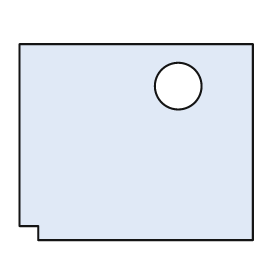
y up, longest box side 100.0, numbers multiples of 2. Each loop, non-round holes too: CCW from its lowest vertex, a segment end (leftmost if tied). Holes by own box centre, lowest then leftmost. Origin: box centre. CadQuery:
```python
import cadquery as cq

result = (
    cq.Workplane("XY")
    .moveTo(-42.0, -42.0)
    .lineTo(50.0, -42.0)
    .lineTo(50.0, 42.0)
    .lineTo(-50.0, 42.0)
    .lineTo(-50.0, -36.0)
    .lineTo(-42.0, -36.0)
    .close()
    .moveTo(18.0, 24.0)
    .circle(10.0)
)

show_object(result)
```